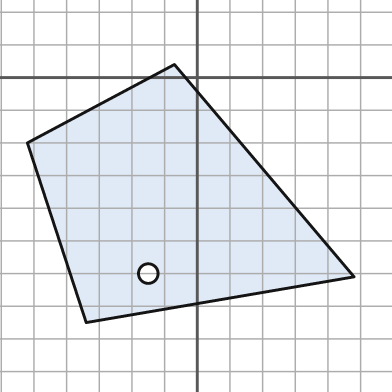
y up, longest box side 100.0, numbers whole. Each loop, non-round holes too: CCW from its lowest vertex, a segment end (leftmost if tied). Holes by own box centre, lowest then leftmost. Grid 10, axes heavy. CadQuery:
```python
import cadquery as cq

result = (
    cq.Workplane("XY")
    .moveTo(-34.0, -75.0)
    .lineTo(48.0, -61.0)
    .lineTo(-7.0, 4.0)
    .lineTo(-52.0, -20.0)
    .close()
    .moveTo(-15.0, -60.0)
    .circle(3.0)
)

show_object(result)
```